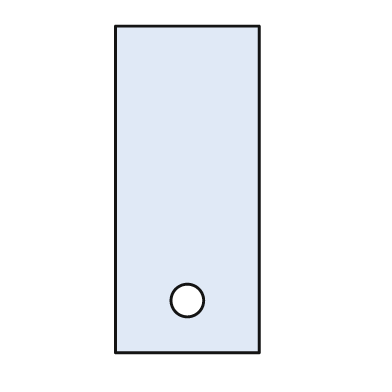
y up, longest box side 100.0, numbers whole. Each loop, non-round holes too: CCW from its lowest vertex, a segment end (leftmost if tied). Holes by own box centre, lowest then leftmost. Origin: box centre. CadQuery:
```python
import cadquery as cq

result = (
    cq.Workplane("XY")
    .moveTo(-22.0, -50.0)
    .lineTo(22.0, -50.0)
    .lineTo(22.0, 50.0)
    .lineTo(-22.0, 50.0)
    .close()
    .moveTo(0.0, -34.0)
    .circle(5.0)
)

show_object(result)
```